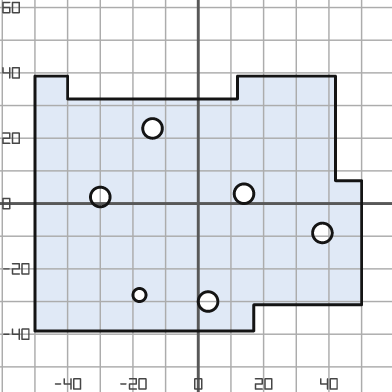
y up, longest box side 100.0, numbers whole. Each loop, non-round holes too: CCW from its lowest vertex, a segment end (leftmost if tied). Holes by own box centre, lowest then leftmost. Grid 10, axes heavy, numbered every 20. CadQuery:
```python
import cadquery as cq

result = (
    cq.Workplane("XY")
    .moveTo(-50.0, -39.0)
    .lineTo(17.0, -39.0)
    .lineTo(17.0, -31.0)
    .lineTo(50.0, -31.0)
    .lineTo(50.0, 7.0)
    .lineTo(42.0, 7.0)
    .lineTo(42.0, 39.0)
    .lineTo(12.0, 39.0)
    .lineTo(12.0, 32.0)
    .lineTo(-40.0, 32.0)
    .lineTo(-40.0, 39.0)
    .lineTo(-50.0, 39.0)
    .close()
    .moveTo(3.0, -30.0)
    .circle(3.0)
    .moveTo(-18.0, -28.0)
    .circle(2.0)
    .moveTo(38.0, -9.0)
    .circle(3.0)
    .moveTo(-30.0, 2.0)
    .circle(3.0)
    .moveTo(14.0, 3.0)
    .circle(3.0)
    .moveTo(-14.0, 23.0)
    .circle(3.0)
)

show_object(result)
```